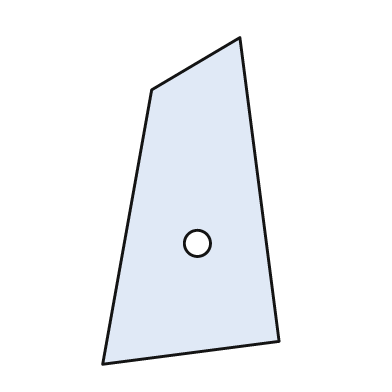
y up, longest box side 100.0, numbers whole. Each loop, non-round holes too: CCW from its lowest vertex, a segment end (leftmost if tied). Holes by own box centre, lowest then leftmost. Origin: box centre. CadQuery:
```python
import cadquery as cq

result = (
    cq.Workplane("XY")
    .moveTo(-27.0, -50.0)
    .lineTo(27.0, -43.0)
    .lineTo(15.0, 50.0)
    .lineTo(-12.0, 34.0)
    .close()
    .moveTo(2.0, -13.0)
    .circle(4.0)
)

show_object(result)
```